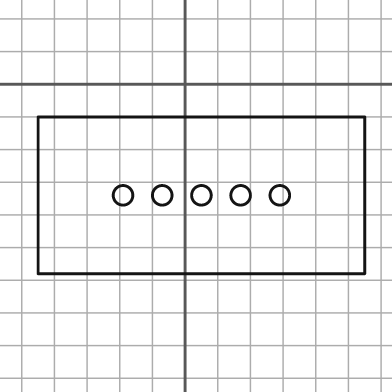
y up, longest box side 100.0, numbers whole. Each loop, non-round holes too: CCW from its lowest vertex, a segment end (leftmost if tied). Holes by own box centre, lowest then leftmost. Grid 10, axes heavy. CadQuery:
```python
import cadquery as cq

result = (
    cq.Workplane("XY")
    .moveTo(-45.0, -58.0)
    .lineTo(55.0, -58.0)
    .lineTo(55.0, -10.0)
    .lineTo(-45.0, -10.0)
    .close()
    .moveTo(-19.0, -34.0)
    .circle(3.0)
    .moveTo(-7.0, -34.0)
    .circle(3.0)
    .moveTo(5.0, -34.0)
    .circle(3.0)
    .moveTo(17.0, -34.0)
    .circle(3.0)
    .moveTo(29.0, -34.0)
    .circle(3.0)
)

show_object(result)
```